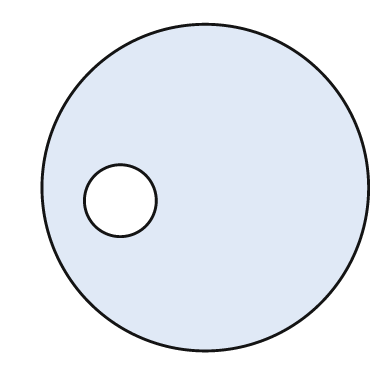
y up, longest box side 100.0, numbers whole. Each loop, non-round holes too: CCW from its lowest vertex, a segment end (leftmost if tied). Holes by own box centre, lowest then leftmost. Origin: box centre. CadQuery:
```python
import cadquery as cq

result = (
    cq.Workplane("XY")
    .moveTo(0.0, 0.0)
    .circle(50.0)
    .moveTo(-26.0, -4.0)
    .circle(11.0)
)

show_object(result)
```